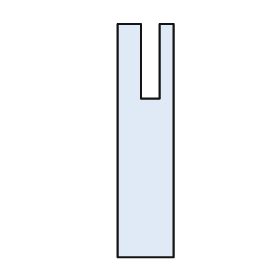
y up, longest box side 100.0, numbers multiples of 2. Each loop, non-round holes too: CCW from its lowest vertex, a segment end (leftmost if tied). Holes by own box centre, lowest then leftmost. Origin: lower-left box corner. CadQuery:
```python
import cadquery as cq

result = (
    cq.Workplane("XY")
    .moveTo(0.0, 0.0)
    .lineTo(24.0, 0.0)
    .lineTo(24.0, 100.0)
    .lineTo(18.0, 100.0)
    .lineTo(18.0, 68.0)
    .lineTo(10.0, 68.0)
    .lineTo(10.0, 100.0)
    .lineTo(0.0, 100.0)
    .close()
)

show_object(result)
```